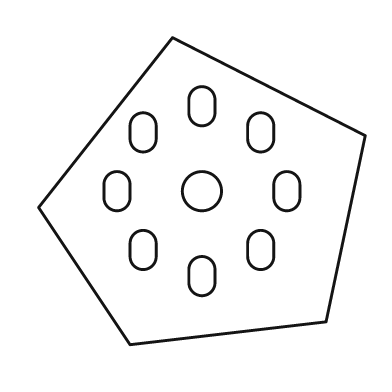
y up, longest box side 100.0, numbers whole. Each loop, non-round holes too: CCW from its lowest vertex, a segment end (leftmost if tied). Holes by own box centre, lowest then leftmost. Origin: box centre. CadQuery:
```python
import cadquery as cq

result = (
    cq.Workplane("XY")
    .moveTo(-22.0, -47.0)
    .lineTo(38.0, -40.0)
    .lineTo(50.0, 17.0)
    .lineTo(-9.0, 47.0)
    .lineTo(-50.0, -5.0)
    .close()
    .moveTo(-4.0, -28.0)
    .threePointArc((0.0, -32.0), (4.0, -28.0))
    .lineTo(4.0, -24.0)
    .threePointArc((0.0, -20.0), (-4.0, -24.0))
    .close()
    .moveTo(-22.0, -20.0)
    .threePointArc((-18.0, -24.0), (-14.0, -20.0))
    .lineTo(-14.0, -16.0)
    .threePointArc((-18.0, -12.0), (-22.0, -16.0))
    .close()
    .moveTo(14.0, -20.0)
    .threePointArc((18.0, -24.0), (22.0, -20.0))
    .lineTo(22.0, -16.0)
    .threePointArc((18.0, -12.0), (14.0, -16.0))
    .close()
    .moveTo(-30.0, -2.0)
    .threePointArc((-26.0, -6.0), (-22.0, -2.0))
    .lineTo(-22.0, 2.0)
    .threePointArc((-26.0, 6.0), (-30.0, 2.0))
    .close()
    .moveTo(0.0, 0.0)
    .circle(6.0)
    .moveTo(22.0, -2.0)
    .threePointArc((26.0, -6.0), (30.0, -2.0))
    .lineTo(30.0, 2.0)
    .threePointArc((26.0, 6.0), (22.0, 2.0))
    .close()
    .moveTo(-22.0, 16.0)
    .threePointArc((-18.0, 12.0), (-14.0, 16.0))
    .lineTo(-14.0, 20.0)
    .threePointArc((-18.0, 24.0), (-22.0, 20.0))
    .close()
    .moveTo(14.0, 16.0)
    .threePointArc((18.0, 12.0), (22.0, 16.0))
    .lineTo(22.0, 20.0)
    .threePointArc((18.0, 24.0), (14.0, 20.0))
    .close()
    .moveTo(-4.0, 24.0)
    .threePointArc((0.0, 20.0), (4.0, 24.0))
    .lineTo(4.0, 28.0)
    .threePointArc((0.0, 32.0), (-4.0, 28.0))
    .close()
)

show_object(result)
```